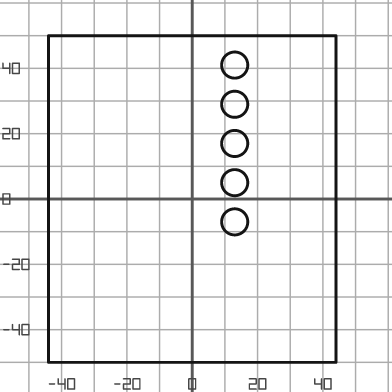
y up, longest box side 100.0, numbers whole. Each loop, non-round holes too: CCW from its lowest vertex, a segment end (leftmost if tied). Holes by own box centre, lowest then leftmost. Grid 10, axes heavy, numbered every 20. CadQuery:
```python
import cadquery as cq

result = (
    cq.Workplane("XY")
    .moveTo(-44.0, -50.0)
    .lineTo(44.0, -50.0)
    .lineTo(44.0, 50.0)
    .lineTo(-44.0, 50.0)
    .close()
    .moveTo(13.0, -7.0)
    .circle(4.0)
    .moveTo(13.0, 5.0)
    .circle(4.0)
    .moveTo(13.0, 17.0)
    .circle(4.0)
    .moveTo(13.0, 29.0)
    .circle(4.0)
    .moveTo(13.0, 41.0)
    .circle(4.0)
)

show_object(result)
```